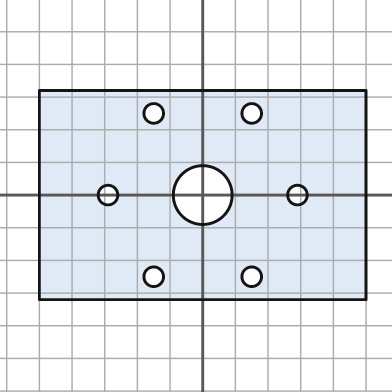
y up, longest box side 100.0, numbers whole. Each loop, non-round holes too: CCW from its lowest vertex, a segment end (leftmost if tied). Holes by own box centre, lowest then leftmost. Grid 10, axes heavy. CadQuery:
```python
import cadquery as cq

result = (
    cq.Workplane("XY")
    .moveTo(-50.0, -32.0)
    .lineTo(50.0, -32.0)
    .lineTo(50.0, 32.0)
    .lineTo(-50.0, 32.0)
    .close()
    .moveTo(-15.0, -25.0)
    .circle(3.0)
    .moveTo(15.0, -25.0)
    .circle(3.0)
    .moveTo(-29.0, 0.0)
    .circle(3.0)
    .moveTo(0.0, 0.0)
    .circle(9.0)
    .moveTo(29.0, 0.0)
    .circle(3.0)
    .moveTo(-15.0, 25.0)
    .circle(3.0)
    .moveTo(15.0, 25.0)
    .circle(3.0)
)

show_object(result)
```